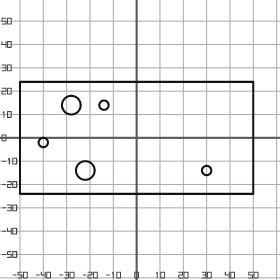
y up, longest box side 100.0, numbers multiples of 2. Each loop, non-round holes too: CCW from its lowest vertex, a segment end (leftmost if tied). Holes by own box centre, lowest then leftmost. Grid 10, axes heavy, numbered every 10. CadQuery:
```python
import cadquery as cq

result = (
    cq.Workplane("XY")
    .moveTo(-50.0, -24.0)
    .lineTo(50.0, -24.0)
    .lineTo(50.0, 24.0)
    .lineTo(-50.0, 24.0)
    .close()
    .moveTo(-22.0, -14.0)
    .circle(4.0)
    .moveTo(30.0, -14.0)
    .circle(2.0)
    .moveTo(-40.0, -2.0)
    .circle(2.0)
    .moveTo(-28.0, 14.0)
    .circle(4.0)
    .moveTo(-14.0, 14.0)
    .circle(2.0)
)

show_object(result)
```